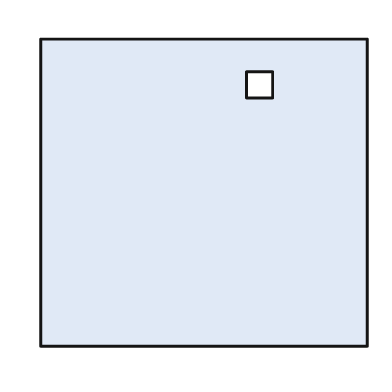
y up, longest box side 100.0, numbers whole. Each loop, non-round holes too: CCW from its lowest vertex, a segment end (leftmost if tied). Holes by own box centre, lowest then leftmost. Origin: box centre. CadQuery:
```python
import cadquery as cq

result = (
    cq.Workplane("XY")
    .moveTo(-50.0, -47.0)
    .lineTo(50.0, -47.0)
    .lineTo(50.0, 47.0)
    .lineTo(-50.0, 47.0)
    .close()
    .moveTo(13.0, 29.0)
    .lineTo(21.0, 29.0)
    .lineTo(21.0, 37.0)
    .lineTo(13.0, 37.0)
    .close()
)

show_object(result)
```